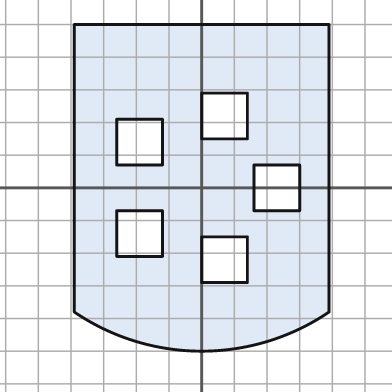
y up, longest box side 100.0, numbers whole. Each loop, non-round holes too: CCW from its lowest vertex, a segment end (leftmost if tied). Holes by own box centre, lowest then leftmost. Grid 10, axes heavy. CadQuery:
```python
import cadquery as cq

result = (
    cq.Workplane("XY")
    .moveTo(-39.0, -38.0)
    .threePointArc((0.0, -50.0), (39.0, -38.0))
    .lineTo(39.0, 50.0)
    .lineTo(-39.0, 50.0)
    .close()
    .moveTo(0.0, -29.0)
    .lineTo(14.0, -29.0)
    .lineTo(14.0, -15.0)
    .lineTo(0.0, -15.0)
    .close()
    .moveTo(-26.0, -21.0)
    .lineTo(-12.0, -21.0)
    .lineTo(-12.0, -7.0)
    .lineTo(-26.0, -7.0)
    .close()
    .moveTo(16.0, -7.0)
    .lineTo(30.0, -7.0)
    .lineTo(30.0, 7.0)
    .lineTo(16.0, 7.0)
    .close()
    .moveTo(-26.0, 7.0)
    .lineTo(-12.0, 7.0)
    .lineTo(-12.0, 21.0)
    .lineTo(-26.0, 21.0)
    .close()
    .moveTo(0.0, 15.0)
    .lineTo(14.0, 15.0)
    .lineTo(14.0, 29.0)
    .lineTo(0.0, 29.0)
    .close()
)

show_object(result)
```